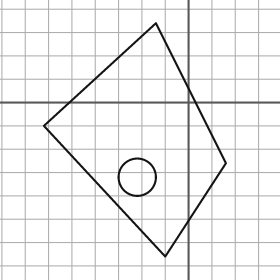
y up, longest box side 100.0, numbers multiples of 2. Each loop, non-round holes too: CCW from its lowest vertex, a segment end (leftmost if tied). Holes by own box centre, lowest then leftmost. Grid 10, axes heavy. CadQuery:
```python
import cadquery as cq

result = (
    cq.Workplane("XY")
    .moveTo(-10.0, -66.0)
    .lineTo(16.0, -26.0)
    .lineTo(-14.0, 34.0)
    .lineTo(-62.0, -10.0)
    .close()
    .moveTo(-22.0, -32.0)
    .circle(8.0)
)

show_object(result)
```